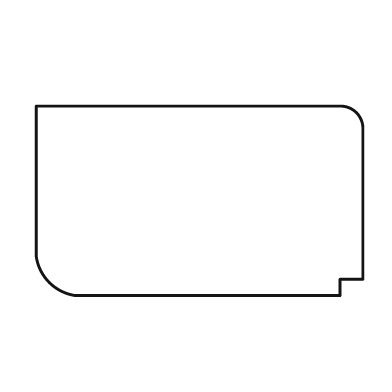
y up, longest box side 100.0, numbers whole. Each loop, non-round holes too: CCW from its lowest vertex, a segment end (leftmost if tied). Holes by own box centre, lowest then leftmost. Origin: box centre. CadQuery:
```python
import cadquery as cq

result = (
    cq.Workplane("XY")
    .moveTo(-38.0, -29.0)
    .lineTo(43.0, -29.0)
    .lineTo(43.0, -24.0)
    .lineTo(50.0, -24.0)
    .lineTo(50.0, 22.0)
    .threePointArc((48.0, 27.0), (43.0, 29.0))
    .lineTo(-50.0, 29.0)
    .lineTo(-50.0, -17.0)
    .threePointArc((-46.0, -25.0), (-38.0, -29.0))
    .close()
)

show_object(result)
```